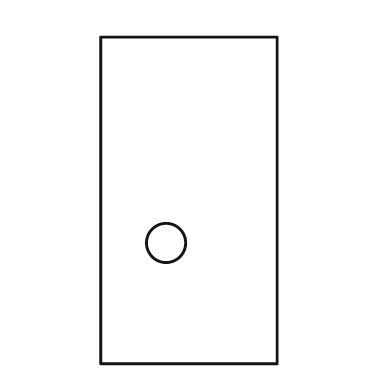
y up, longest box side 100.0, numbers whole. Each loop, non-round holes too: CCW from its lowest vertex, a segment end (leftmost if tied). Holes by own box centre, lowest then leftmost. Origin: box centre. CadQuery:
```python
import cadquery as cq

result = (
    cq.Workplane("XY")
    .moveTo(-27.0, -50.0)
    .lineTo(27.0, -50.0)
    .lineTo(27.0, 50.0)
    .lineTo(-27.0, 50.0)
    .close()
    .moveTo(-7.0, -13.0)
    .circle(6.0)
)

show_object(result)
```